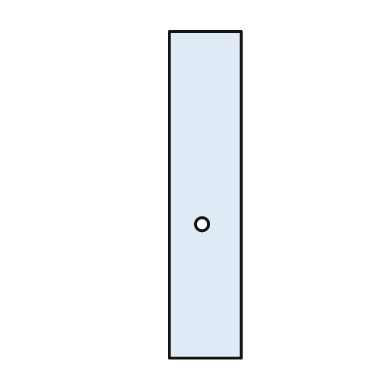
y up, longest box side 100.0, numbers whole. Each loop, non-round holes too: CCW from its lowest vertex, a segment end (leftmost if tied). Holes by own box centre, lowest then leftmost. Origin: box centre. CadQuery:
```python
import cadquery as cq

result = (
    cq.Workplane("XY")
    .moveTo(-11.0, -50.0)
    .lineTo(11.0, -50.0)
    .lineTo(11.0, 50.0)
    .lineTo(-11.0, 50.0)
    .close()
    .moveTo(-1.0, -9.0)
    .circle(2.0)
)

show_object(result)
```